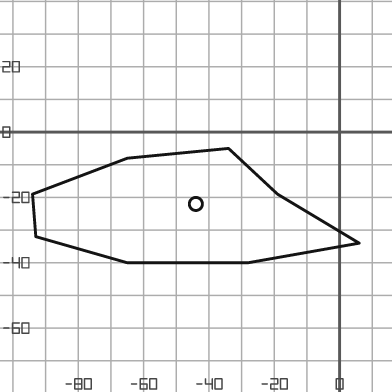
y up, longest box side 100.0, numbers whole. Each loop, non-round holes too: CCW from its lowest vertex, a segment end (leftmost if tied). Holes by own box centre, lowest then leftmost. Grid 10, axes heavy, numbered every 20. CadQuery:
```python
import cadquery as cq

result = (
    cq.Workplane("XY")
    .moveTo(-65.0, -40.0)
    .lineTo(-28.0, -40.0)
    .lineTo(6.0, -34.0)
    .lineTo(-19.0, -19.0)
    .lineTo(-34.0, -5.0)
    .lineTo(-65.0, -8.0)
    .lineTo(-94.0, -19.0)
    .lineTo(-93.0, -32.0)
    .close()
    .moveTo(-44.0, -22.0)
    .circle(2.0)
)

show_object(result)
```